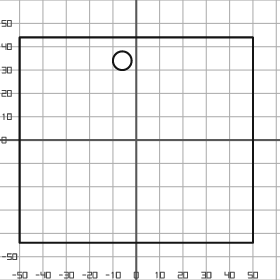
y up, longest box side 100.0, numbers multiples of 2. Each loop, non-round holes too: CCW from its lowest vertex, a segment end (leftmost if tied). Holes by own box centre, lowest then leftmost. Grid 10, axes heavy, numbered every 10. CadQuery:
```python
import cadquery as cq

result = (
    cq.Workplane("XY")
    .moveTo(-50.0, -44.0)
    .lineTo(50.0, -44.0)
    .lineTo(50.0, 44.0)
    .lineTo(-50.0, 44.0)
    .close()
    .moveTo(-6.0, 34.0)
    .circle(4.0)
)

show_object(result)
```